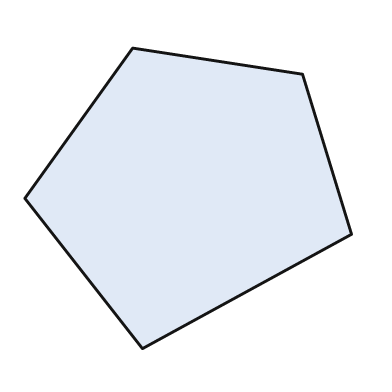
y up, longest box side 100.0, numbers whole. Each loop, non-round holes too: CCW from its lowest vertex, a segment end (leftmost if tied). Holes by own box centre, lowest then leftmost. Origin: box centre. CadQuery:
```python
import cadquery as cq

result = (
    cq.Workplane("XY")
    .moveTo(-14.0, -46.0)
    .lineTo(50.0, -11.0)
    .lineTo(35.0, 38.0)
    .lineTo(-17.0, 46.0)
    .lineTo(-50.0, 0.0)
    .close()
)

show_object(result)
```